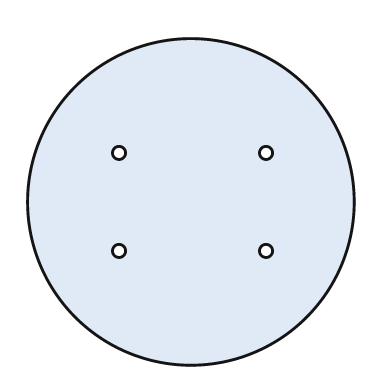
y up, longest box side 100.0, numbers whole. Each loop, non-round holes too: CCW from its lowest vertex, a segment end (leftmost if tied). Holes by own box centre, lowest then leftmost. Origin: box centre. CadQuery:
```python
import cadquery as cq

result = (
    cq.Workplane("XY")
    .moveTo(0.0, 0.0)
    .circle(50.0)
    .moveTo(-22.0, -15.0)
    .circle(2.0)
    .moveTo(23.0, -15.0)
    .circle(2.0)
    .moveTo(-22.0, 15.0)
    .circle(2.0)
    .moveTo(23.0, 15.0)
    .circle(2.0)
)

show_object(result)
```